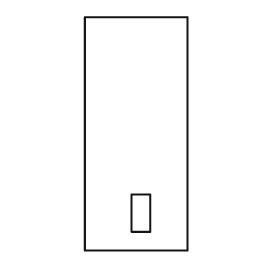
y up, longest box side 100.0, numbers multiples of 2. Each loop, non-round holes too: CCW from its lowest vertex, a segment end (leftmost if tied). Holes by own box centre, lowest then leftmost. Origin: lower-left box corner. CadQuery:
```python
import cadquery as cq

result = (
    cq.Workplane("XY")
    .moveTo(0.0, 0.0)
    .lineTo(44.0, 0.0)
    .lineTo(44.0, 100.0)
    .lineTo(0.0, 100.0)
    .close()
    .moveTo(20.0, 8.0)
    .lineTo(28.0, 8.0)
    .lineTo(28.0, 24.0)
    .lineTo(20.0, 24.0)
    .close()
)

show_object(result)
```